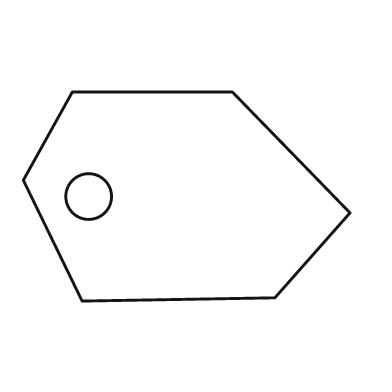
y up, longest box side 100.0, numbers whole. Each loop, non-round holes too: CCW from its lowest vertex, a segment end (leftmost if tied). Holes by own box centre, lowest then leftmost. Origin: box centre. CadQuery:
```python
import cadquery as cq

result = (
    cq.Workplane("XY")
    .moveTo(-32.0, -32.0)
    .lineTo(27.0, -31.0)
    .lineTo(50.0, -5.0)
    .lineTo(14.0, 32.0)
    .lineTo(-35.0, 32.0)
    .lineTo(-50.0, 5.0)
    .close()
    .moveTo(-30.0, 0.0)
    .circle(7.0)
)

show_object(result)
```